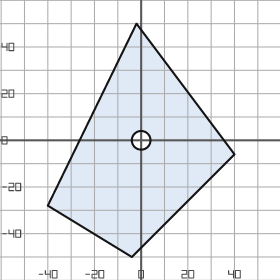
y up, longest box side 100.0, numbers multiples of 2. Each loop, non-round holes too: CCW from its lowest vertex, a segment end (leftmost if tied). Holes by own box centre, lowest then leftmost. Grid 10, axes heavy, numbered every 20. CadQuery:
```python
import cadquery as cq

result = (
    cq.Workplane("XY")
    .moveTo(-4.0, -50.0)
    .lineTo(40.0, -6.0)
    .lineTo(-2.0, 50.0)
    .lineTo(-40.0, -28.0)
    .close()
    .moveTo(0.0, 0.0)
    .circle(4.0)
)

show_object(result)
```